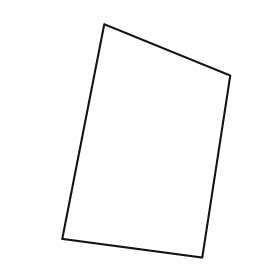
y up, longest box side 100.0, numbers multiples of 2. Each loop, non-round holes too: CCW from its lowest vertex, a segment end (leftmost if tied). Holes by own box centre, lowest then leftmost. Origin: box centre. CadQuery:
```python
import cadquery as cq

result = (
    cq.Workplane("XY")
    .moveTo(24.0, -50.0)
    .lineTo(36.0, 28.0)
    .lineTo(-18.0, 50.0)
    .lineTo(-36.0, -42.0)
    .close()
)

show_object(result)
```